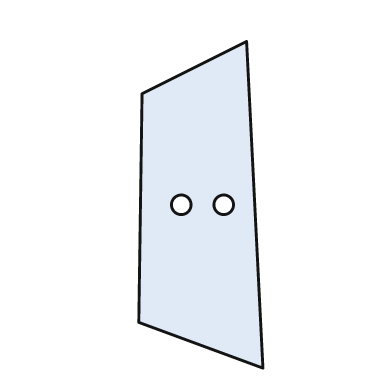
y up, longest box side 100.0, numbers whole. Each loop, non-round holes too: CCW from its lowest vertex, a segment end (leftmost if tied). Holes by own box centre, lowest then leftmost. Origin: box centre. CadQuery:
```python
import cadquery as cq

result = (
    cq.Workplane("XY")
    .moveTo(19.0, -50.0)
    .lineTo(14.0, 50.0)
    .lineTo(-18.0, 34.0)
    .lineTo(-19.0, -36.0)
    .close()
    .moveTo(-6.0, 0.0)
    .circle(3.0)
    .moveTo(7.0, 0.0)
    .circle(3.0)
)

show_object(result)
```